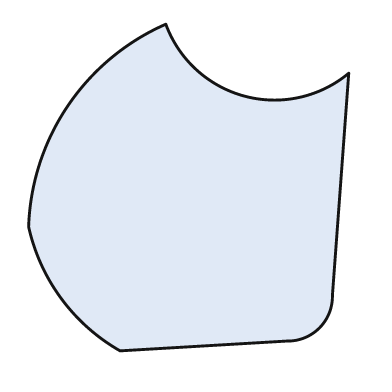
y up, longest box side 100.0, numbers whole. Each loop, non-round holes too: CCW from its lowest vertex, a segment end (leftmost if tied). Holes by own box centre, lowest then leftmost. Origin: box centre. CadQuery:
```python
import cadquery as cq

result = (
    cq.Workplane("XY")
    .moveTo(-21.0, -50.0)
    .lineTo(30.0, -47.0)
    .threePointArc((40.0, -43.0), (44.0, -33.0))
    .lineTo(49.0, 35.0)
    .threePointArc((17.0, 28.0), (-7.0, 50.0))
    .threePointArc((-37.0, 25.0), (-49.0, -12.0))
    .threePointArc((-39.0, -34.0), (-21.0, -50.0))
    .close()
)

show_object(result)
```